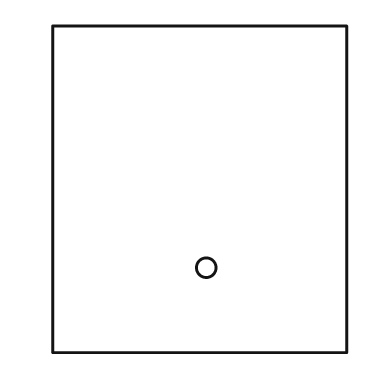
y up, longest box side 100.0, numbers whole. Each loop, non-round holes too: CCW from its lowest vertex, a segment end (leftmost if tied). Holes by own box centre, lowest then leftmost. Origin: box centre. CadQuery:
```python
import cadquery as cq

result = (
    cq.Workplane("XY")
    .moveTo(-45.0, -50.0)
    .lineTo(45.0, -50.0)
    .lineTo(45.0, 50.0)
    .lineTo(-45.0, 50.0)
    .close()
    .moveTo(2.0, -24.0)
    .circle(3.0)
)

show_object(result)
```